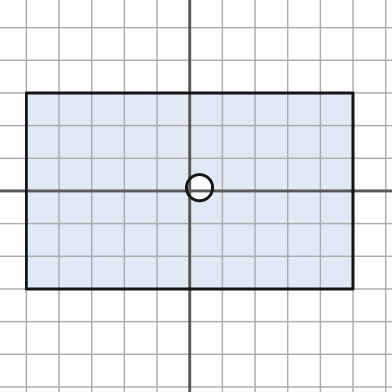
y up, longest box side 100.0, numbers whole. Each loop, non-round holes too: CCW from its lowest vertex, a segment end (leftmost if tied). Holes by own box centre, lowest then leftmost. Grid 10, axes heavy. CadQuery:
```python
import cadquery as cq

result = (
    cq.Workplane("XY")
    .moveTo(-50.0, -30.0)
    .lineTo(50.0, -30.0)
    .lineTo(50.0, 30.0)
    .lineTo(-50.0, 30.0)
    .close()
    .moveTo(3.0, 1.0)
    .circle(4.0)
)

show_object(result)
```